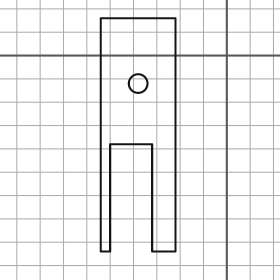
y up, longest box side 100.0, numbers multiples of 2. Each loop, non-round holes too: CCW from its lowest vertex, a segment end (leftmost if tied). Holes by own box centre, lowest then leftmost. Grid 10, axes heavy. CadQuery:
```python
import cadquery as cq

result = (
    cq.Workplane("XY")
    .moveTo(-54.0, -84.0)
    .lineTo(-50.0, -84.0)
    .lineTo(-50.0, -38.0)
    .lineTo(-32.0, -38.0)
    .lineTo(-32.0, -84.0)
    .lineTo(-22.0, -84.0)
    .lineTo(-22.0, 16.0)
    .lineTo(-54.0, 16.0)
    .close()
    .moveTo(-38.0, -12.0)
    .circle(4.0)
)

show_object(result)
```